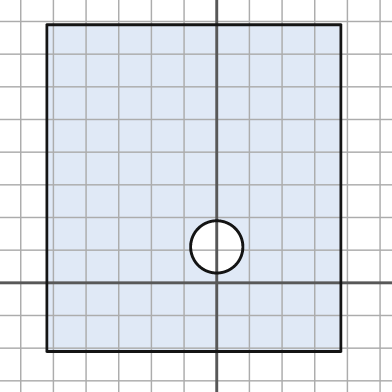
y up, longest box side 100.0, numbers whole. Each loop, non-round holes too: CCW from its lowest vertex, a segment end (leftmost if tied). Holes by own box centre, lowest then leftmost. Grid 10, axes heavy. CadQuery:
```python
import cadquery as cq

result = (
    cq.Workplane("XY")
    .moveTo(-52.0, -21.0)
    .lineTo(38.0, -21.0)
    .lineTo(38.0, 79.0)
    .lineTo(-52.0, 79.0)
    .close()
    .moveTo(0.0, 11.0)
    .circle(8.0)
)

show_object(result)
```